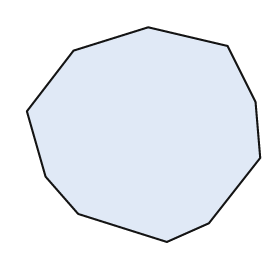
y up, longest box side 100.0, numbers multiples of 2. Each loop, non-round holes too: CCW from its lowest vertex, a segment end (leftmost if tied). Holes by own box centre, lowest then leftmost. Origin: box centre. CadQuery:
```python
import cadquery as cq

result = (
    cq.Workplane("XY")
    .moveTo(10.0, -46.0)
    .lineTo(28.0, -38.0)
    .lineTo(50.0, -10.0)
    .lineTo(48.0, 14.0)
    .lineTo(36.0, 38.0)
    .lineTo(2.0, 46.0)
    .lineTo(-30.0, 36.0)
    .lineTo(-50.0, 10.0)
    .lineTo(-42.0, -18.0)
    .lineTo(-28.0, -34.0)
    .close()
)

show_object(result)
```